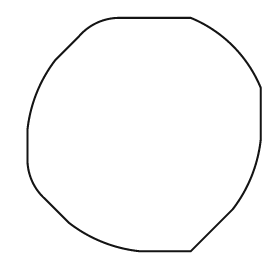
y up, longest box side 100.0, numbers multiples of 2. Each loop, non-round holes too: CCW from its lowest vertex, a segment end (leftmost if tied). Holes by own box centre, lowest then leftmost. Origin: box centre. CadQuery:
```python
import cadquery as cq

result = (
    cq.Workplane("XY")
    .moveTo(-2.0, -50.0)
    .lineTo(20.0, -50.0)
    .lineTo(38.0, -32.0)
    .threePointArc((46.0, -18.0), (50.0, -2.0))
    .lineTo(50.0, 20.0)
    .threePointArc((38.0, 38.0), (20.0, 50.0))
    .lineTo(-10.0, 50.0)
    .threePointArc((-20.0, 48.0), (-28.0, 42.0))
    .lineTo(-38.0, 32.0)
    .threePointArc((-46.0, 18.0), (-50.0, 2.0))
    .lineTo(-50.0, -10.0)
    .threePointArc((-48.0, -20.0), (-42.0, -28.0))
    .lineTo(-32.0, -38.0)
    .threePointArc((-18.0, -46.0), (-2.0, -50.0))
    .close()
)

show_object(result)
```